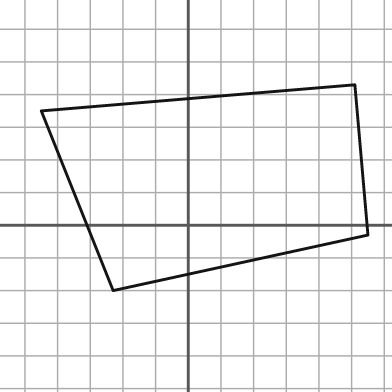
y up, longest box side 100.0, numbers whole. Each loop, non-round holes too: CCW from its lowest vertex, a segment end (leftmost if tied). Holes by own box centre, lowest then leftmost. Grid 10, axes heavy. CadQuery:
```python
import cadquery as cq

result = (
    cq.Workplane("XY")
    .moveTo(-23.0, -20.0)
    .lineTo(55.0, -3.0)
    .lineTo(51.0, 43.0)
    .lineTo(-45.0, 35.0)
    .close()
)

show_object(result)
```